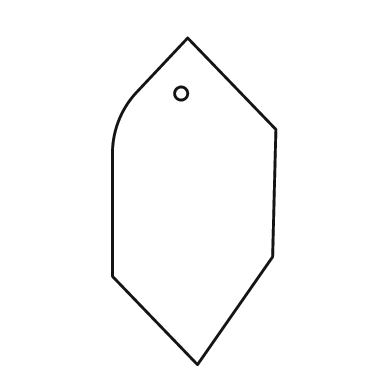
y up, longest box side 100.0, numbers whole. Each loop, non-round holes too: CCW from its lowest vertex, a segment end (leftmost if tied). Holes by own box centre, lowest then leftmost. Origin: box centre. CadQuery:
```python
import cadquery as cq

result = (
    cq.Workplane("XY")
    .moveTo(1.0, -50.0)
    .lineTo(24.0, -17.0)
    .lineTo(25.0, 22.0)
    .lineTo(-2.0, 50.0)
    .lineTo(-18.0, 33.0)
    .threePointArc((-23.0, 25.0), (-25.0, 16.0))
    .lineTo(-25.0, -23.0)
    .close()
    .moveTo(-4.0, 33.0)
    .circle(2.0)
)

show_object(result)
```